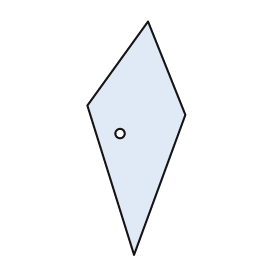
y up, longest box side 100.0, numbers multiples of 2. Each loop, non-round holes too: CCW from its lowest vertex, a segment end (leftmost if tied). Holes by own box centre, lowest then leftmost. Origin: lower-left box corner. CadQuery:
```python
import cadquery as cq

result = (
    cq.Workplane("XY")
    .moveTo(20.0, 0.0)
    .lineTo(42.0, 60.0)
    .lineTo(26.0, 100.0)
    .lineTo(0.0, 64.0)
    .close()
    .moveTo(14.0, 52.0)
    .circle(2.0)
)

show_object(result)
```